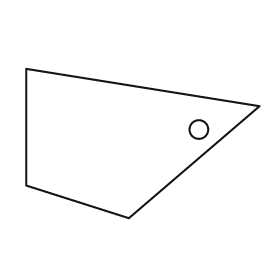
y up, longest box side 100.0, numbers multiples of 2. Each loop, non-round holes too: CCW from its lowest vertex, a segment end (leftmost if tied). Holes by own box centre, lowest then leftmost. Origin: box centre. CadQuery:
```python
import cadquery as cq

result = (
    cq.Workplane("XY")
    .moveTo(-6.0, -32.0)
    .lineTo(50.0, 16.0)
    .lineTo(-50.0, 32.0)
    .lineTo(-50.0, -18.0)
    .close()
    .moveTo(24.0, 6.0)
    .circle(4.0)
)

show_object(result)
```